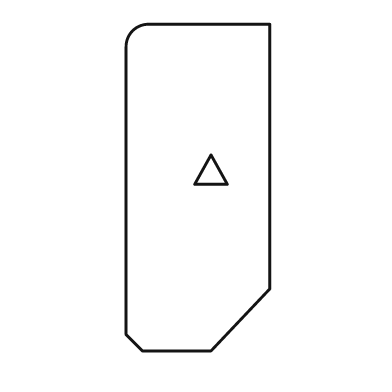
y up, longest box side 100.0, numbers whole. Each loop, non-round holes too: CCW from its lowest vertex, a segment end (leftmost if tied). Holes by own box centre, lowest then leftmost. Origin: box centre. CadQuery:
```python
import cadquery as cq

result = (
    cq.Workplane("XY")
    .moveTo(-17.0, -50.0)
    .lineTo(4.0, -50.0)
    .lineTo(22.0, -31.0)
    .lineTo(22.0, 50.0)
    .lineTo(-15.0, 50.0)
    .threePointArc((-20.0, 48.0), (-22.0, 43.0))
    .lineTo(-22.0, -45.0)
    .close()
    .moveTo(-1.0, 1.0)
    .lineTo(9.0, 1.0)
    .lineTo(4.0, 10.0)
    .close()
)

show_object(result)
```